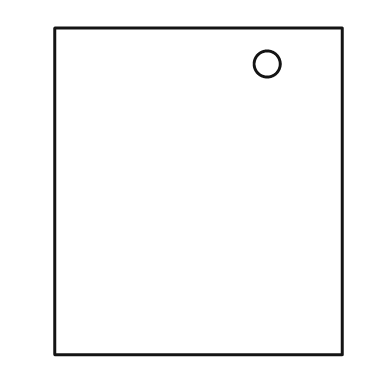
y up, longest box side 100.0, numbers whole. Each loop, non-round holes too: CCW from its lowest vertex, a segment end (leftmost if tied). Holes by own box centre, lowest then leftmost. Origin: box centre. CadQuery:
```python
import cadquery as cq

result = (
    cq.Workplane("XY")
    .moveTo(-44.0, -50.0)
    .lineTo(44.0, -50.0)
    .lineTo(44.0, 50.0)
    .lineTo(-44.0, 50.0)
    .close()
    .moveTo(21.0, 39.0)
    .circle(4.0)
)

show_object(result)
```